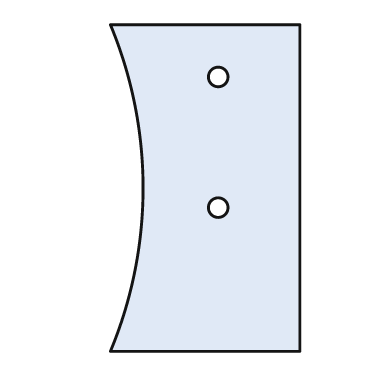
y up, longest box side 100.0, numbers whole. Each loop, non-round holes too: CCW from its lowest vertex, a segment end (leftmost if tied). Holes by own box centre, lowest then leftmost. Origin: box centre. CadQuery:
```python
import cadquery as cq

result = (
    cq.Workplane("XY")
    .moveTo(-29.0, -50.0)
    .lineTo(29.0, -50.0)
    .lineTo(29.0, 50.0)
    .lineTo(-29.0, 50.0)
    .threePointArc((-19.0, 0.0), (-29.0, -50.0))
    .close()
    .moveTo(4.0, -6.0)
    .circle(3.0)
    .moveTo(4.0, 34.0)
    .circle(3.0)
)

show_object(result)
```